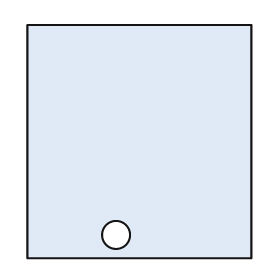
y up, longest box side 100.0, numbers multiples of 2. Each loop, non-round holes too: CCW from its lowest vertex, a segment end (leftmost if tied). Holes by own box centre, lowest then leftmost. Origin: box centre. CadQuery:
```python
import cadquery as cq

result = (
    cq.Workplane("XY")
    .moveTo(-48.0, -50.0)
    .lineTo(48.0, -50.0)
    .lineTo(48.0, 50.0)
    .lineTo(-48.0, 50.0)
    .close()
    .moveTo(-10.0, -40.0)
    .circle(6.0)
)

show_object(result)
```